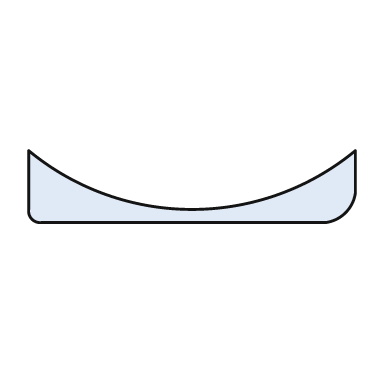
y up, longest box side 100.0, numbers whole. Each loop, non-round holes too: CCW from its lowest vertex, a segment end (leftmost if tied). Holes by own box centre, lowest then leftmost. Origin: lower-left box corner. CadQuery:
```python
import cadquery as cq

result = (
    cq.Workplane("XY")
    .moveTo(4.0, 0.0)
    .lineTo(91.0, 0.0)
    .threePointArc((97.0, 3.0), (100.0, 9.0))
    .lineTo(100.0, 22.0)
    .threePointArc((50.0, 4.0), (0.0, 22.0))
    .lineTo(0.0, 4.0)
    .threePointArc((1.0, 1.0), (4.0, 0.0))
    .close()
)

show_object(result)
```